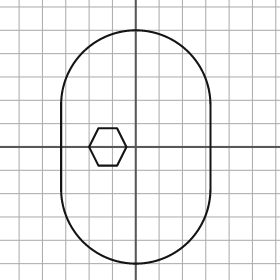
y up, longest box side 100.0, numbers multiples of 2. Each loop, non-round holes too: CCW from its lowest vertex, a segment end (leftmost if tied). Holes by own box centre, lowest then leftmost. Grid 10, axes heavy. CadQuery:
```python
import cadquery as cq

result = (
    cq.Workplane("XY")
    .moveTo(-32.0, -18.0)
    .threePointArc((0.0, -50.0), (32.0, -18.0))
    .lineTo(32.0, 18.0)
    .threePointArc((0.0, 50.0), (-32.0, 18.0))
    .close()
    .moveTo(-16.0, -8.0)
    .lineTo(-8.0, -8.0)
    .lineTo(-4.0, 0.0)
    .lineTo(-8.0, 8.0)
    .lineTo(-16.0, 8.0)
    .lineTo(-20.0, 0.0)
    .close()
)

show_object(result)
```